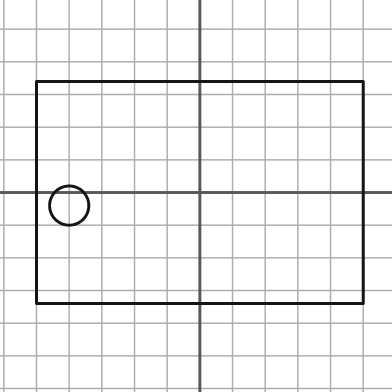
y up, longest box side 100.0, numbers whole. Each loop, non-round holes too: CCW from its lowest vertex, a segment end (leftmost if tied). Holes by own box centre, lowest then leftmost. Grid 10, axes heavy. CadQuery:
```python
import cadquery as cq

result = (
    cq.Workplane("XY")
    .moveTo(-50.0, -34.0)
    .lineTo(50.0, -34.0)
    .lineTo(50.0, 34.0)
    .lineTo(-50.0, 34.0)
    .close()
    .moveTo(-40.0, -4.0)
    .circle(6.0)
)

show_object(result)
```